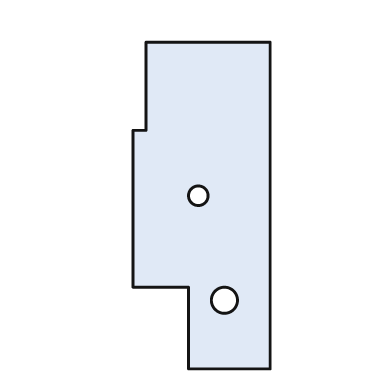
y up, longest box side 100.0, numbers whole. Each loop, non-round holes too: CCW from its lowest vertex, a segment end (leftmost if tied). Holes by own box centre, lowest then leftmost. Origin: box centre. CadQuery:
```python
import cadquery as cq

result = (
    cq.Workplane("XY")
    .moveTo(-4.0, -50.0)
    .lineTo(21.0, -50.0)
    .lineTo(21.0, 50.0)
    .lineTo(-17.0, 50.0)
    .lineTo(-17.0, 23.0)
    .lineTo(-21.0, 23.0)
    .lineTo(-21.0, -25.0)
    .lineTo(-4.0, -25.0)
    .close()
    .moveTo(7.0, -29.0)
    .circle(4.0)
    .moveTo(-1.0, 3.0)
    .circle(3.0)
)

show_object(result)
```